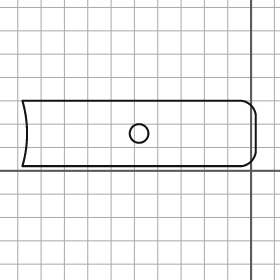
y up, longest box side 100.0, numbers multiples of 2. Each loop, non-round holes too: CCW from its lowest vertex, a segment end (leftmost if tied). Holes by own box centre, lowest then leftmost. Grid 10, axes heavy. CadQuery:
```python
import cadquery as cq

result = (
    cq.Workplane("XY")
    .moveTo(-98.0, 2.0)
    .lineTo(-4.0, 2.0)
    .threePointArc((0.0, 4.0), (2.0, 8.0))
    .lineTo(2.0, 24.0)
    .threePointArc((0.0, 28.0), (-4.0, 30.0))
    .lineTo(-98.0, 30.0)
    .threePointArc((-96.0, 16.0), (-98.0, 2.0))
    .close()
    .moveTo(-48.0, 16.0)
    .circle(4.0)
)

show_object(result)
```